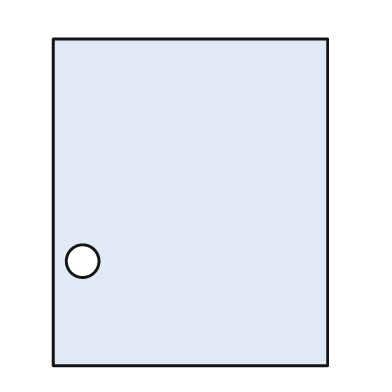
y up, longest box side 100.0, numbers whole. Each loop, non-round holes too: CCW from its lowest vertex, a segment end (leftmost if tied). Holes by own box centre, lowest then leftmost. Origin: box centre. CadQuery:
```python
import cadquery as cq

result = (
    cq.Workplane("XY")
    .moveTo(-42.0, -50.0)
    .lineTo(42.0, -50.0)
    .lineTo(42.0, 50.0)
    .lineTo(-42.0, 50.0)
    .close()
    .moveTo(-33.0, -18.0)
    .circle(5.0)
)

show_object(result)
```